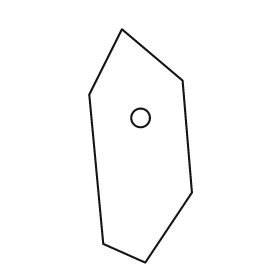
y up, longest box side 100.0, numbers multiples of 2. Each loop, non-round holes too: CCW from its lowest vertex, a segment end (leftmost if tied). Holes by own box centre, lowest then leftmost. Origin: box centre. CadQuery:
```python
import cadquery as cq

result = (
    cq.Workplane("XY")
    .moveTo(2.0, -50.0)
    .lineTo(22.0, -20.0)
    .lineTo(18.0, 28.0)
    .lineTo(-8.0, 50.0)
    .lineTo(-22.0, 22.0)
    .lineTo(-16.0, -42.0)
    .close()
    .moveTo(0.0, 12.0)
    .circle(4.0)
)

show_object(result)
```